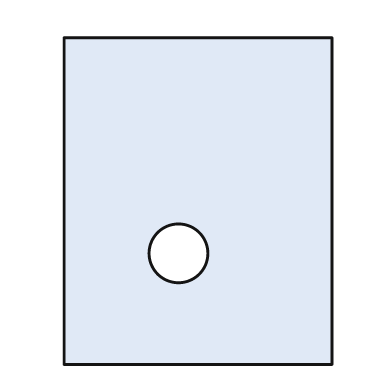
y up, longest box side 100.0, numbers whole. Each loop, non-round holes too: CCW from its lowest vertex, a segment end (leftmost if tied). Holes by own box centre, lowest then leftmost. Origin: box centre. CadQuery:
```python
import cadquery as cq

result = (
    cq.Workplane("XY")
    .moveTo(-41.0, -50.0)
    .lineTo(41.0, -50.0)
    .lineTo(41.0, 50.0)
    .lineTo(-41.0, 50.0)
    .close()
    .moveTo(-6.0, -16.0)
    .circle(9.0)
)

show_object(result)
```